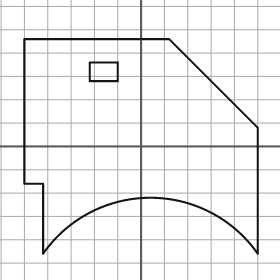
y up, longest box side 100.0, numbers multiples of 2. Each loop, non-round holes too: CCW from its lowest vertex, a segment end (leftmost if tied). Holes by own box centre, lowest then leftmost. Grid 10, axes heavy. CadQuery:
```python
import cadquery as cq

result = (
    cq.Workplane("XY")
    .moveTo(-42.0, -46.0)
    .threePointArc((4.0, -22.0), (50.0, -46.0))
    .lineTo(50.0, 8.0)
    .lineTo(12.0, 46.0)
    .lineTo(-50.0, 46.0)
    .lineTo(-50.0, -16.0)
    .lineTo(-42.0, -16.0)
    .close()
    .moveTo(-22.0, 28.0)
    .lineTo(-10.0, 28.0)
    .lineTo(-10.0, 36.0)
    .lineTo(-22.0, 36.0)
    .close()
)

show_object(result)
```